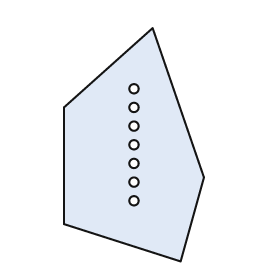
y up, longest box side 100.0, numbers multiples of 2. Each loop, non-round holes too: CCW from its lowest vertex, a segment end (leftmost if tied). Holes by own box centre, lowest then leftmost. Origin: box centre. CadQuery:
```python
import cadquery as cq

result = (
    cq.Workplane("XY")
    .moveTo(20.0, -50.0)
    .lineTo(30.0, -14.0)
    .lineTo(8.0, 50.0)
    .lineTo(-30.0, 16.0)
    .lineTo(-30.0, -34.0)
    .close()
    .moveTo(0.0, -24.0)
    .circle(2.0)
    .moveTo(0.0, -16.0)
    .circle(2.0)
    .moveTo(0.0, -8.0)
    .circle(2.0)
    .moveTo(0.0, 0.0)
    .circle(2.0)
    .moveTo(0.0, 8.0)
    .circle(2.0)
    .moveTo(0.0, 16.0)
    .circle(2.0)
    .moveTo(0.0, 24.0)
    .circle(2.0)
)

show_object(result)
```